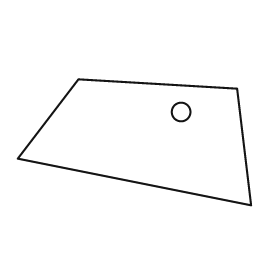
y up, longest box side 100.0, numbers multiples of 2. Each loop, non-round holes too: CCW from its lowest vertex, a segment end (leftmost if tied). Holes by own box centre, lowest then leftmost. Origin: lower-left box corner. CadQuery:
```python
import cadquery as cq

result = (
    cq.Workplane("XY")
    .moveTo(100.0, 0.0)
    .lineTo(94.0, 50.0)
    .lineTo(26.0, 54.0)
    .lineTo(0.0, 20.0)
    .close()
    .moveTo(70.0, 40.0)
    .circle(4.0)
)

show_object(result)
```